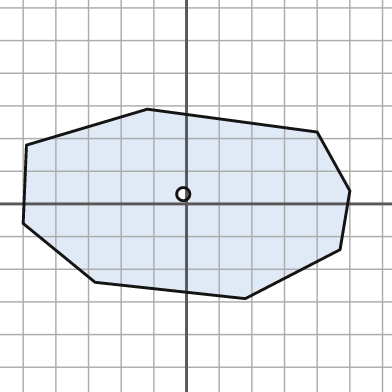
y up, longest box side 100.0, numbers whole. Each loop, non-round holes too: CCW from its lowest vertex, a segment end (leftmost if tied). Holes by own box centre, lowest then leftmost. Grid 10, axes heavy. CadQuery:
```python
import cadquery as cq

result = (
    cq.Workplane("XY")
    .moveTo(18.0, -29.0)
    .lineTo(47.0, -14.0)
    .lineTo(50.0, 4.0)
    .lineTo(40.0, 22.0)
    .lineTo(-12.0, 29.0)
    .lineTo(-49.0, 18.0)
    .lineTo(-50.0, -6.0)
    .lineTo(-28.0, -24.0)
    .close()
    .moveTo(-1.0, 3.0)
    .circle(2.0)
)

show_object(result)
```